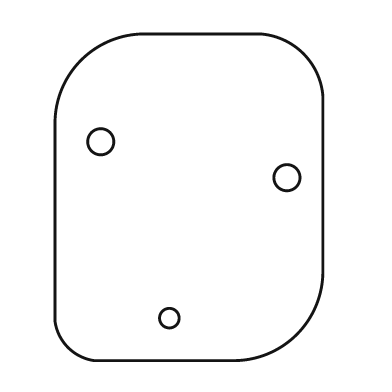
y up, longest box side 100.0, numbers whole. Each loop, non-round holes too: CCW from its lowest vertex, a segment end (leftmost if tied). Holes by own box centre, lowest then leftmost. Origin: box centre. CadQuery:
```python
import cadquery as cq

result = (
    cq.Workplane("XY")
    .moveTo(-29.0, -50.0)
    .lineTo(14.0, -50.0)
    .threePointArc((33.0, -42.0), (41.0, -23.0))
    .lineTo(41.0, 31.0)
    .threePointArc((35.0, 44.0), (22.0, 50.0))
    .lineTo(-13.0, 50.0)
    .threePointArc((-33.0, 42.0), (-41.0, 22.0))
    .lineTo(-41.0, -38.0)
    .threePointArc((-37.0, -46.0), (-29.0, -50.0))
    .close()
    .moveTo(-6.0, -37.0)
    .circle(3.0)
    .moveTo(30.0, 6.0)
    .circle(4.0)
    .moveTo(-27.0, 17.0)
    .circle(4.0)
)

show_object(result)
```